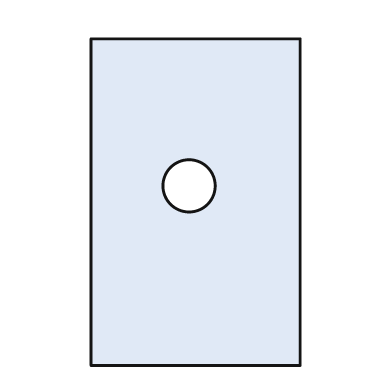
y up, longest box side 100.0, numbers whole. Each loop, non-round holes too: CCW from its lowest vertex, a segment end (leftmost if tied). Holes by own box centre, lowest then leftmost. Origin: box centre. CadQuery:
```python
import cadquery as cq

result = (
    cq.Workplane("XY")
    .moveTo(-32.0, -50.0)
    .lineTo(32.0, -50.0)
    .lineTo(32.0, 50.0)
    .lineTo(-32.0, 50.0)
    .close()
    .moveTo(-2.0, 5.0)
    .circle(8.0)
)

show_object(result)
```